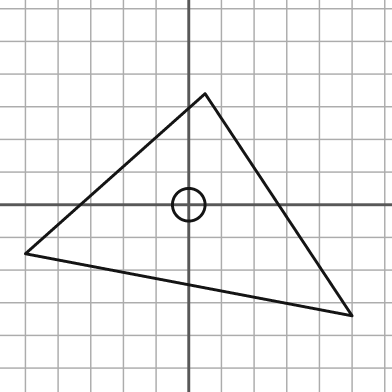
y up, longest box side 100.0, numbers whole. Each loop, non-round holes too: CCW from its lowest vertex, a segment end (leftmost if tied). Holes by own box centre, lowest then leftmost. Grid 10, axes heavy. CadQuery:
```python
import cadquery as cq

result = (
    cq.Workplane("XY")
    .moveTo(50.0, -34.0)
    .lineTo(5.0, 34.0)
    .lineTo(-50.0, -15.0)
    .close()
    .moveTo(0.0, 0.0)
    .circle(5.0)
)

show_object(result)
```